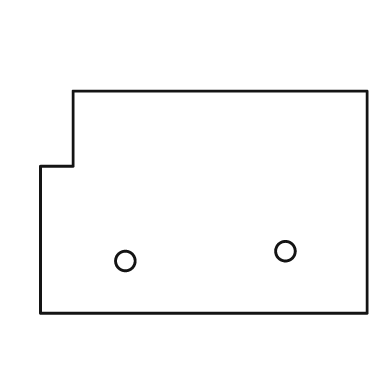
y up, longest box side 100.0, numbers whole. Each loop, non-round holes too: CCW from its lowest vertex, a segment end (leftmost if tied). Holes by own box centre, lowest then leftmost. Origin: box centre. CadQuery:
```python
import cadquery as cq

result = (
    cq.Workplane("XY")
    .moveTo(-50.0, -34.0)
    .lineTo(50.0, -34.0)
    .lineTo(50.0, 34.0)
    .lineTo(-40.0, 34.0)
    .lineTo(-40.0, 11.0)
    .lineTo(-50.0, 11.0)
    .close()
    .moveTo(-24.0, -18.0)
    .circle(3.0)
    .moveTo(25.0, -15.0)
    .circle(3.0)
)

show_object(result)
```